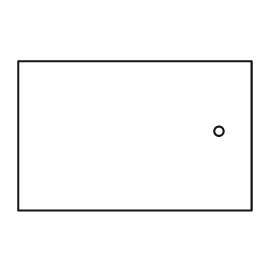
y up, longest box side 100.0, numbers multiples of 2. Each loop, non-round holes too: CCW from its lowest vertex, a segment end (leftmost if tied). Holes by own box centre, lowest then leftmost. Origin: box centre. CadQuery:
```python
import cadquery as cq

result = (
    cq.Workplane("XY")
    .moveTo(-50.0, -32.0)
    .lineTo(50.0, -32.0)
    .lineTo(50.0, 32.0)
    .lineTo(-50.0, 32.0)
    .close()
    .moveTo(36.0, 2.0)
    .circle(2.0)
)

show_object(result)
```